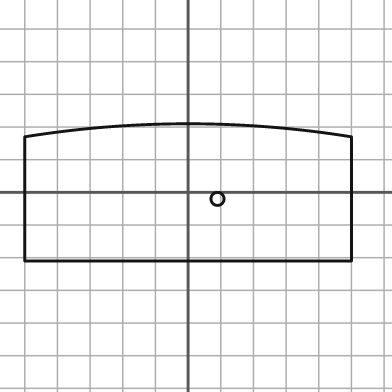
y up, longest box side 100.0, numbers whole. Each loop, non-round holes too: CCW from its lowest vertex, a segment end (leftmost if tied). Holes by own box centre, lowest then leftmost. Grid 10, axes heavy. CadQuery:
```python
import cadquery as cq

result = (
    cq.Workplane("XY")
    .moveTo(-50.0, -21.0)
    .lineTo(50.0, -21.0)
    .lineTo(50.0, 17.0)
    .threePointArc((0.0, 21.0), (-50.0, 17.0))
    .close()
    .moveTo(9.0, -2.0)
    .circle(2.0)
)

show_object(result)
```